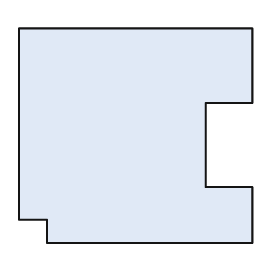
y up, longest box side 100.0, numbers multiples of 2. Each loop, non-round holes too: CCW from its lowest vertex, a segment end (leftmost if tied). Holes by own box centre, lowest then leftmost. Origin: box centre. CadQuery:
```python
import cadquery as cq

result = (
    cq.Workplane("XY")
    .moveTo(-38.0, -46.0)
    .lineTo(50.0, -46.0)
    .lineTo(50.0, -22.0)
    .lineTo(30.0, -22.0)
    .lineTo(30.0, 14.0)
    .lineTo(50.0, 14.0)
    .lineTo(50.0, 46.0)
    .lineTo(-50.0, 46.0)
    .lineTo(-50.0, -36.0)
    .lineTo(-38.0, -36.0)
    .close()
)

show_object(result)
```